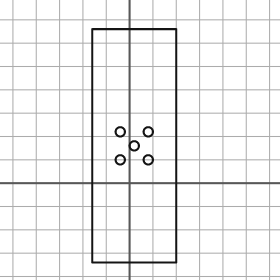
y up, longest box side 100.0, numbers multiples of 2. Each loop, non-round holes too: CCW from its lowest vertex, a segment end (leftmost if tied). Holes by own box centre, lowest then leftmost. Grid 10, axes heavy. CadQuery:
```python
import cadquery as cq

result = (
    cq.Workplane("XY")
    .moveTo(-16.0, -34.0)
    .lineTo(20.0, -34.0)
    .lineTo(20.0, 66.0)
    .lineTo(-16.0, 66.0)
    .close()
    .moveTo(-4.0, 10.0)
    .circle(2.0)
    .moveTo(8.0, 10.0)
    .circle(2.0)
    .moveTo(2.0, 16.0)
    .circle(2.0)
    .moveTo(-4.0, 22.0)
    .circle(2.0)
    .moveTo(8.0, 22.0)
    .circle(2.0)
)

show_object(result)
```